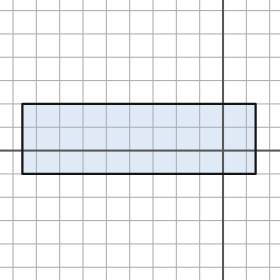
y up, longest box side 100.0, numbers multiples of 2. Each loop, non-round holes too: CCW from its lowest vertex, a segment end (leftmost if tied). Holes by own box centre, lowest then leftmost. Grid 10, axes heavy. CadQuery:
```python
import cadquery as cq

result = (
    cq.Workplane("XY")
    .moveTo(-86.0, -10.0)
    .lineTo(14.0, -10.0)
    .lineTo(14.0, 20.0)
    .lineTo(-86.0, 20.0)
    .close()
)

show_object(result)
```